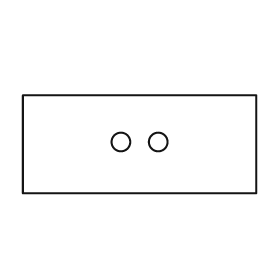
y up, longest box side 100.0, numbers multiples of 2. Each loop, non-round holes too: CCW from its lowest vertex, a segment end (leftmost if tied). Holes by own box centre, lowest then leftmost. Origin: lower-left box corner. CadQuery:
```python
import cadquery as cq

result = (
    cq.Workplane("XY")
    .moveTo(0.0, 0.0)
    .lineTo(100.0, 0.0)
    .lineTo(100.0, 42.0)
    .lineTo(0.0, 42.0)
    .close()
    .moveTo(42.0, 22.0)
    .circle(4.0)
    .moveTo(58.0, 22.0)
    .circle(4.0)
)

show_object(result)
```